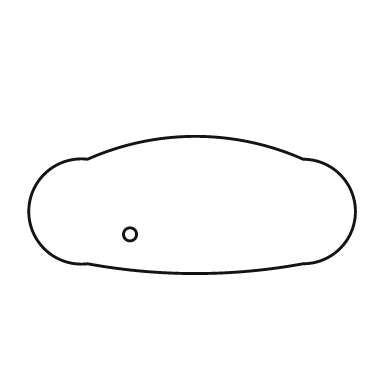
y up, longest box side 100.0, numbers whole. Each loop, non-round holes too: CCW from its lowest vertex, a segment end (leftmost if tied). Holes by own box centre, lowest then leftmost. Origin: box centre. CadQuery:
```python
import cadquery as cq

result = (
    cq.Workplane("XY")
    .moveTo(-32.0, -18.0)
    .threePointArc((1.0, -21.0), (34.0, -18.0))
    .threePointArc((50.0, -2.0), (34.0, 14.0))
    .threePointArc((1.0, 21.0), (-32.0, 14.0))
    .threePointArc((-50.0, -2.0), (-32.0, -18.0))
    .close()
    .moveTo(-19.0, -9.0)
    .circle(2.0)
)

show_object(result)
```